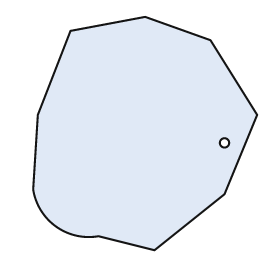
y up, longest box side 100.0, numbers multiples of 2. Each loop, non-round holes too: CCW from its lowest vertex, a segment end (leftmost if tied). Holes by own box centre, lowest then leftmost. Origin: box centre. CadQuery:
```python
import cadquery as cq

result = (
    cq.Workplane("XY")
    .moveTo(4.0, -50.0)
    .lineTo(34.0, -26.0)
    .lineTo(48.0, 8.0)
    .lineTo(28.0, 40.0)
    .lineTo(0.0, 50.0)
    .lineTo(-32.0, 44.0)
    .lineTo(-46.0, 8.0)
    .lineTo(-48.0, -24.0)
    .threePointArc((-38.0, -40.0), (-20.0, -44.0))
    .close()
    .moveTo(34.0, -4.0)
    .circle(2.0)
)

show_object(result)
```